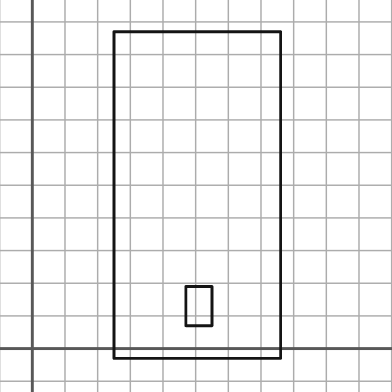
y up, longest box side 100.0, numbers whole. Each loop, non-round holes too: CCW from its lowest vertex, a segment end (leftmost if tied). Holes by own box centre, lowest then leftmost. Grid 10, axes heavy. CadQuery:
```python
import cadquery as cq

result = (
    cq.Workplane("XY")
    .moveTo(25.0, -3.0)
    .lineTo(76.0, -3.0)
    .lineTo(76.0, 97.0)
    .lineTo(25.0, 97.0)
    .close()
    .moveTo(47.0, 7.0)
    .lineTo(55.0, 7.0)
    .lineTo(55.0, 19.0)
    .lineTo(47.0, 19.0)
    .close()
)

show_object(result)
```